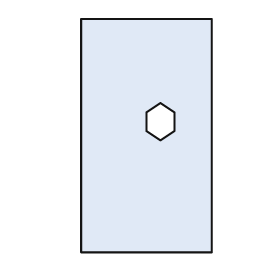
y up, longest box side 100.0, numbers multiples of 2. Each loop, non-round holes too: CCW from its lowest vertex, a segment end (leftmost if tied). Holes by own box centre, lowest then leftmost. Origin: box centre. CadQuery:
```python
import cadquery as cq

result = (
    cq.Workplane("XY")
    .moveTo(-28.0, -50.0)
    .lineTo(28.0, -50.0)
    .lineTo(28.0, 50.0)
    .lineTo(-28.0, 50.0)
    .close()
    .moveTo(6.0, -2.0)
    .lineTo(12.0, 2.0)
    .lineTo(12.0, 10.0)
    .lineTo(6.0, 14.0)
    .lineTo(0.0, 10.0)
    .lineTo(0.0, 2.0)
    .close()
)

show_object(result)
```